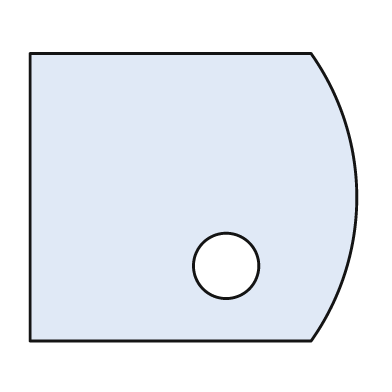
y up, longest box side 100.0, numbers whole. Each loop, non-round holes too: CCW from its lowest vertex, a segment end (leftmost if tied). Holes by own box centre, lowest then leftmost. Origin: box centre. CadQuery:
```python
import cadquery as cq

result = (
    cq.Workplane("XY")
    .moveTo(-50.0, -44.0)
    .lineTo(36.0, -44.0)
    .threePointArc((50.0, 0.0), (36.0, 44.0))
    .lineTo(-50.0, 44.0)
    .close()
    .moveTo(10.0, -21.0)
    .circle(10.0)
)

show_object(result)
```